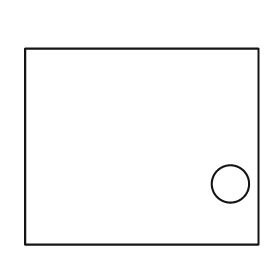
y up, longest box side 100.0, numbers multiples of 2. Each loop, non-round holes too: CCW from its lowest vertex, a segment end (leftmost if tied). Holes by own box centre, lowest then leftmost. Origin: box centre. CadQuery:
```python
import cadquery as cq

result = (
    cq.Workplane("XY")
    .moveTo(-50.0, -42.0)
    .lineTo(50.0, -42.0)
    .lineTo(50.0, 42.0)
    .lineTo(-50.0, 42.0)
    .close()
    .moveTo(38.0, -16.0)
    .circle(8.0)
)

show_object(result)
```